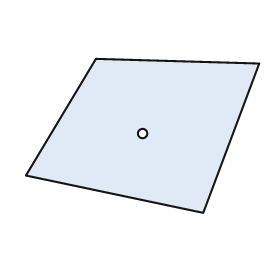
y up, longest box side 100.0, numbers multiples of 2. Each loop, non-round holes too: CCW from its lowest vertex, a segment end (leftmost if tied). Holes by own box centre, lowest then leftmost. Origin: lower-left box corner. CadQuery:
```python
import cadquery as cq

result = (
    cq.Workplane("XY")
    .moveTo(76.0, 0.0)
    .lineTo(100.0, 64.0)
    .lineTo(30.0, 66.0)
    .lineTo(0.0, 16.0)
    .close()
    .moveTo(50.0, 34.0)
    .circle(2.0)
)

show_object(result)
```